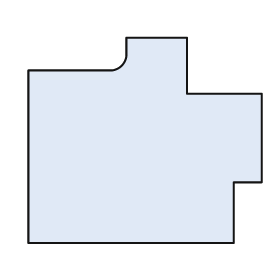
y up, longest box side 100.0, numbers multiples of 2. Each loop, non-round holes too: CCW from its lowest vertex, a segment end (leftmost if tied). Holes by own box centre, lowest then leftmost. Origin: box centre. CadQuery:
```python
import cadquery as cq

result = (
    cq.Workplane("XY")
    .moveTo(-50.0, -44.0)
    .lineTo(38.0, -44.0)
    .lineTo(38.0, -18.0)
    .lineTo(50.0, -18.0)
    .lineTo(50.0, 20.0)
    .lineTo(18.0, 20.0)
    .lineTo(18.0, 44.0)
    .lineTo(-8.0, 44.0)
    .lineTo(-8.0, 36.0)
    .threePointArc((-10.0, 32.0), (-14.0, 30.0))
    .lineTo(-50.0, 30.0)
    .close()
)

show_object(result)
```